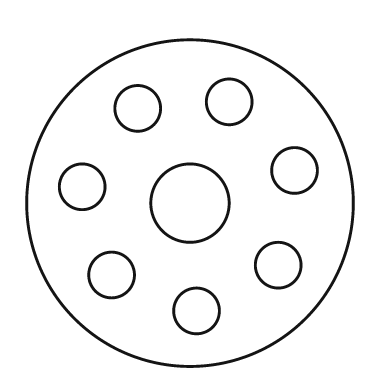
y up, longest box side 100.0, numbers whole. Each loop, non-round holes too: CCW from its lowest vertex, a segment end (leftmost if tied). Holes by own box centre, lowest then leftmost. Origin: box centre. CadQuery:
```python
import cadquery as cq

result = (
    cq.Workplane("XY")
    .moveTo(0.0, 0.0)
    .circle(50.0)
    .moveTo(2.0, -33.0)
    .circle(7.0)
    .moveTo(-24.0, -22.0)
    .circle(7.0)
    .moveTo(27.0, -19.0)
    .circle(7.0)
    .moveTo(0.0, 0.0)
    .circle(12.0)
    .moveTo(-33.0, 5.0)
    .circle(7.0)
    .moveTo(32.0, 10.0)
    .circle(7.0)
    .moveTo(-16.0, 29.0)
    .circle(7.0)
    .moveTo(12.0, 31.0)
    .circle(7.0)
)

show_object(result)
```